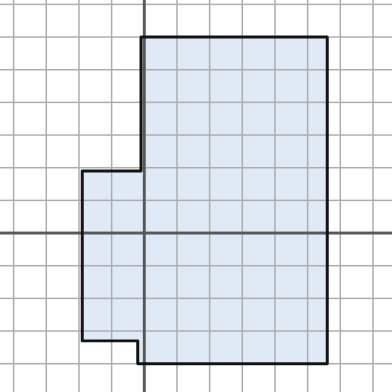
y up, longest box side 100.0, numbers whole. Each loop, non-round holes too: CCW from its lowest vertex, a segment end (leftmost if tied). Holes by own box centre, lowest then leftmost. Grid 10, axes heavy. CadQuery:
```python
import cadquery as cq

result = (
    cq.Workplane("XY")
    .moveTo(-2.0, -40.0)
    .lineTo(56.0, -40.0)
    .lineTo(56.0, 60.0)
    .lineTo(-1.0, 60.0)
    .lineTo(-1.0, 19.0)
    .lineTo(-19.0, 19.0)
    .lineTo(-19.0, -33.0)
    .lineTo(-2.0, -33.0)
    .close()
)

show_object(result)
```